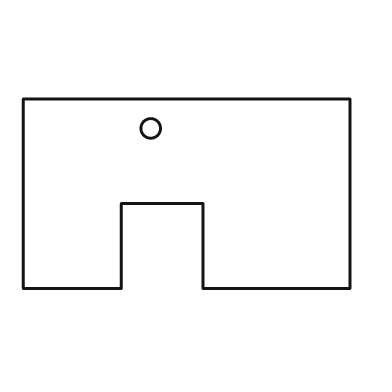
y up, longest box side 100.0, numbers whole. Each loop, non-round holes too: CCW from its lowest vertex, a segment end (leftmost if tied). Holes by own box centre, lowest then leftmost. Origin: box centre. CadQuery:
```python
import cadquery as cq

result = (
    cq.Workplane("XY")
    .moveTo(-50.0, -29.0)
    .lineTo(-20.0, -29.0)
    .lineTo(-20.0, -3.0)
    .lineTo(5.0, -3.0)
    .lineTo(5.0, -29.0)
    .lineTo(50.0, -29.0)
    .lineTo(50.0, 29.0)
    .lineTo(-50.0, 29.0)
    .close()
    .moveTo(-11.0, 20.0)
    .circle(3.0)
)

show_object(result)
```